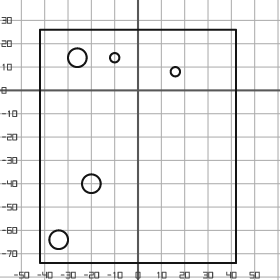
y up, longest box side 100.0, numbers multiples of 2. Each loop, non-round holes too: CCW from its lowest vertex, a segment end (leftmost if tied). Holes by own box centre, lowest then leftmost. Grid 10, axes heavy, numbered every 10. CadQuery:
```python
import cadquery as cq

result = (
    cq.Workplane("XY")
    .moveTo(-42.0, -74.0)
    .lineTo(42.0, -74.0)
    .lineTo(42.0, 26.0)
    .lineTo(-42.0, 26.0)
    .close()
    .moveTo(-34.0, -64.0)
    .circle(4.0)
    .moveTo(-20.0, -40.0)
    .circle(4.0)
    .moveTo(16.0, 8.0)
    .circle(2.0)
    .moveTo(-26.0, 14.0)
    .circle(4.0)
    .moveTo(-10.0, 14.0)
    .circle(2.0)
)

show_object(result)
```